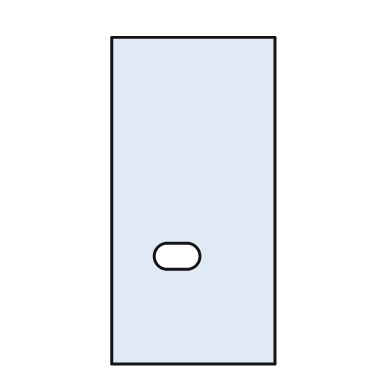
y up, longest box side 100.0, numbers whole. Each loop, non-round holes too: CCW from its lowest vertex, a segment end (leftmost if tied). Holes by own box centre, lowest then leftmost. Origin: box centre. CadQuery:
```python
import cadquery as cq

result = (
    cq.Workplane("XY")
    .moveTo(-25.0, -50.0)
    .lineTo(25.0, -50.0)
    .lineTo(25.0, 50.0)
    .lineTo(-25.0, 50.0)
    .close()
    .moveTo(-8.0, -21.0)
    .lineTo(-2.0, -21.0)
    .threePointArc((2.0, -17.0), (-2.0, -13.0))
    .lineTo(-8.0, -13.0)
    .threePointArc((-12.0, -17.0), (-8.0, -21.0))
    .close()
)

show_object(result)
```